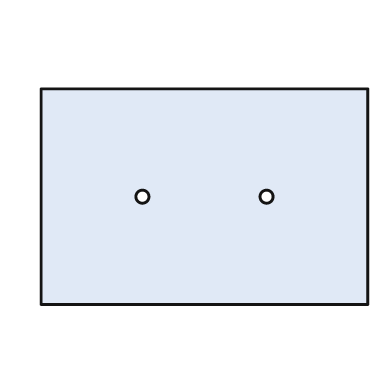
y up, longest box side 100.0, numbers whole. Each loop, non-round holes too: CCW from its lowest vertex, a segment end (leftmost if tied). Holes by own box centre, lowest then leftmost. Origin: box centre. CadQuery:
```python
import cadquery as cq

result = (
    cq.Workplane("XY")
    .moveTo(-50.0, -33.0)
    .lineTo(50.0, -33.0)
    .lineTo(50.0, 33.0)
    .lineTo(-50.0, 33.0)
    .close()
    .moveTo(-19.0, 0.0)
    .circle(2.0)
    .moveTo(19.0, 0.0)
    .circle(2.0)
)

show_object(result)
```